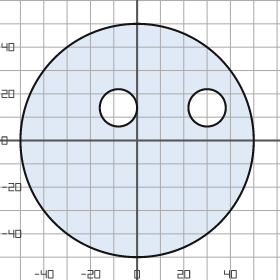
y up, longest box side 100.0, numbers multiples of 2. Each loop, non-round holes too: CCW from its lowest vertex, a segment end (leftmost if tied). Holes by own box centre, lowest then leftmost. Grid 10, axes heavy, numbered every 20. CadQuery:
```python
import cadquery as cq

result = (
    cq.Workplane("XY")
    .moveTo(0.0, 0.0)
    .circle(50.0)
    .moveTo(-8.0, 14.0)
    .circle(8.0)
    .moveTo(30.0, 14.0)
    .circle(8.0)
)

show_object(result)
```